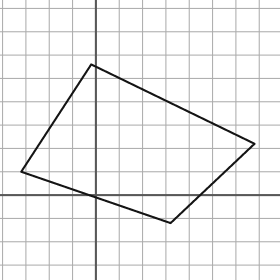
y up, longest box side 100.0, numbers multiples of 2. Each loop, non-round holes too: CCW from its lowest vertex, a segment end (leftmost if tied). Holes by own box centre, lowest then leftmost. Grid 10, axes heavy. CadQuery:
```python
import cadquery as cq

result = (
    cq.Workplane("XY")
    .moveTo(32.0, -12.0)
    .lineTo(68.0, 22.0)
    .lineTo(-2.0, 56.0)
    .lineTo(-32.0, 10.0)
    .close()
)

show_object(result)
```